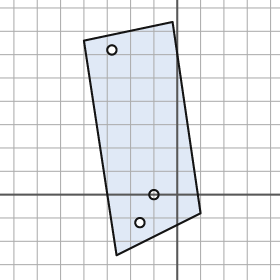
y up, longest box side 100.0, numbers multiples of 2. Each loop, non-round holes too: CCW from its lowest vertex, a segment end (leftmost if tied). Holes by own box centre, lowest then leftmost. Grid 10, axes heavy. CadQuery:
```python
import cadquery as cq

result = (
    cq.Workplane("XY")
    .moveTo(-26.0, -26.0)
    .lineTo(10.0, -8.0)
    .lineTo(-2.0, 74.0)
    .lineTo(-40.0, 66.0)
    .close()
    .moveTo(-16.0, -12.0)
    .circle(2.0)
    .moveTo(-10.0, 0.0)
    .circle(2.0)
    .moveTo(-28.0, 62.0)
    .circle(2.0)
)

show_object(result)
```